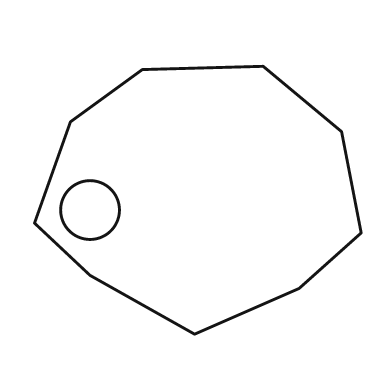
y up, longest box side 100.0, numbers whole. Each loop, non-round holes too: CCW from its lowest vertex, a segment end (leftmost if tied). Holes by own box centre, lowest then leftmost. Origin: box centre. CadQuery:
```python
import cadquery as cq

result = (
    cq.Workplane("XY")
    .moveTo(-1.0, -41.0)
    .lineTo(31.0, -27.0)
    .lineTo(50.0, -10.0)
    .lineTo(44.0, 21.0)
    .lineTo(20.0, 41.0)
    .lineTo(-17.0, 40.0)
    .lineTo(-39.0, 24.0)
    .lineTo(-50.0, -7.0)
    .lineTo(-33.0, -23.0)
    .close()
    .moveTo(-33.0, -3.0)
    .circle(9.0)
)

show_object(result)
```